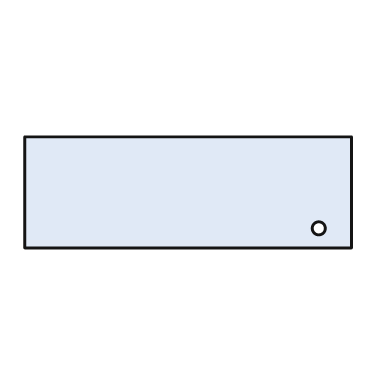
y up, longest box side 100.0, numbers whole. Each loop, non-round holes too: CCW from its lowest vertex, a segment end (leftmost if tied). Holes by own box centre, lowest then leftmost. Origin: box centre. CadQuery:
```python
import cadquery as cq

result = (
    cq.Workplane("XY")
    .moveTo(-50.0, -17.0)
    .lineTo(50.0, -17.0)
    .lineTo(50.0, 17.0)
    .lineTo(-50.0, 17.0)
    .close()
    .moveTo(40.0, -11.0)
    .circle(2.0)
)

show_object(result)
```